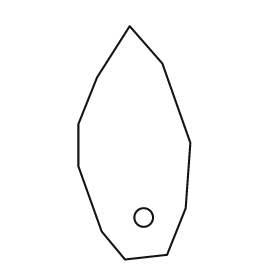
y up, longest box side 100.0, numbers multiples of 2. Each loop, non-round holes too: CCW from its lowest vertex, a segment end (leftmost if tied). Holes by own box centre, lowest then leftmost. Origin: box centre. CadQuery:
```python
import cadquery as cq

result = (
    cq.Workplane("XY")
    .moveTo(-4.0, -50.0)
    .lineTo(14.0, -48.0)
    .lineTo(22.0, -28.0)
    .lineTo(24.0, 0.0)
    .lineTo(12.0, 34.0)
    .lineTo(-2.0, 50.0)
    .lineTo(-16.0, 28.0)
    .lineTo(-24.0, 8.0)
    .lineTo(-24.0, -10.0)
    .lineTo(-14.0, -38.0)
    .close()
    .moveTo(4.0, -32.0)
    .circle(4.0)
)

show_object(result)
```